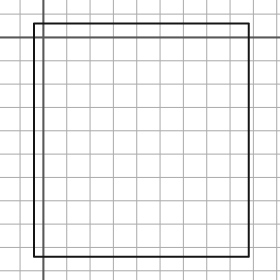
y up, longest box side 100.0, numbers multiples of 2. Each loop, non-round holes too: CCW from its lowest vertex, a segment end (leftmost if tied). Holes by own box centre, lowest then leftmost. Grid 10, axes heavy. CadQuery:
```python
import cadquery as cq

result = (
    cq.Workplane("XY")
    .moveTo(-4.0, -94.0)
    .lineTo(88.0, -94.0)
    .lineTo(88.0, 6.0)
    .lineTo(-4.0, 6.0)
    .close()
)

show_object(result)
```